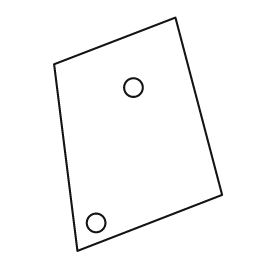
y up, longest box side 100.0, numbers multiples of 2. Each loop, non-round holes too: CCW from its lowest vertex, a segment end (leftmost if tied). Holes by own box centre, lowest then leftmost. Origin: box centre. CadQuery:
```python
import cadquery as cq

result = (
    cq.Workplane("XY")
    .moveTo(-26.0, -50.0)
    .lineTo(36.0, -26.0)
    .lineTo(16.0, 50.0)
    .lineTo(-36.0, 30.0)
    .close()
    .moveTo(-18.0, -38.0)
    .circle(4.0)
    .moveTo(-2.0, 20.0)
    .circle(4.0)
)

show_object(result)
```